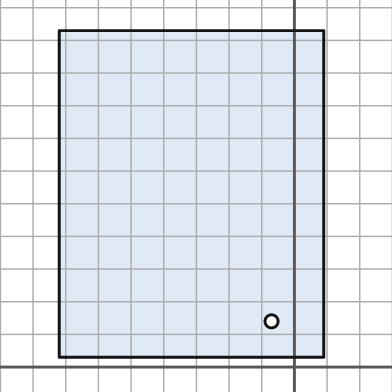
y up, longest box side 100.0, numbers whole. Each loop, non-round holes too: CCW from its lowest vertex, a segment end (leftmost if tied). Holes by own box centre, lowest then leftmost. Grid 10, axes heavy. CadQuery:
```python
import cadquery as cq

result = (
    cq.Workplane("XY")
    .moveTo(-72.0, 3.0)
    .lineTo(9.0, 3.0)
    .lineTo(9.0, 103.0)
    .lineTo(-72.0, 103.0)
    .close()
    .moveTo(-7.0, 14.0)
    .circle(2.0)
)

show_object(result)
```